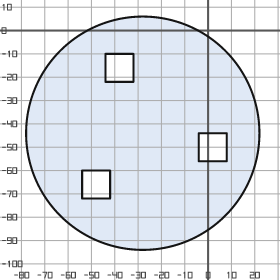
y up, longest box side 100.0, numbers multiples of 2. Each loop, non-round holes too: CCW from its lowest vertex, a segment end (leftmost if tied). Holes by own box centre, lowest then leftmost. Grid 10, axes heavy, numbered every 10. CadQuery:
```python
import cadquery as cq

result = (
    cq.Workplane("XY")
    .moveTo(-28.0, -44.0)
    .circle(50.0)
    .moveTo(-54.0, -72.0)
    .lineTo(-42.0, -72.0)
    .lineTo(-42.0, -60.0)
    .lineTo(-54.0, -60.0)
    .close()
    .moveTo(-4.0, -56.0)
    .lineTo(8.0, -56.0)
    .lineTo(8.0, -44.0)
    .lineTo(-4.0, -44.0)
    .close()
    .moveTo(-44.0, -22.0)
    .lineTo(-32.0, -22.0)
    .lineTo(-32.0, -10.0)
    .lineTo(-44.0, -10.0)
    .close()
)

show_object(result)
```